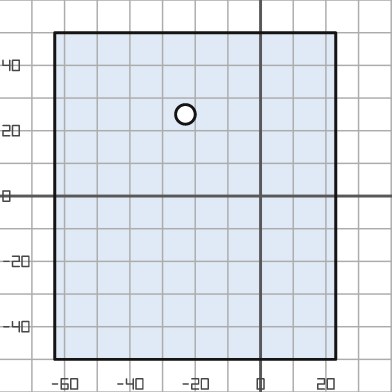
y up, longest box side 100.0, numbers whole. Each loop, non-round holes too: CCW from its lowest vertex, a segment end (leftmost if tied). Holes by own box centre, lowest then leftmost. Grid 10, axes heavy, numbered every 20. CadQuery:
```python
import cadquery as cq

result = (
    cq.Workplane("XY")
    .moveTo(-63.0, -50.0)
    .lineTo(23.0, -50.0)
    .lineTo(23.0, 50.0)
    .lineTo(-63.0, 50.0)
    .close()
    .moveTo(-23.0, 25.0)
    .circle(3.0)
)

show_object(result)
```